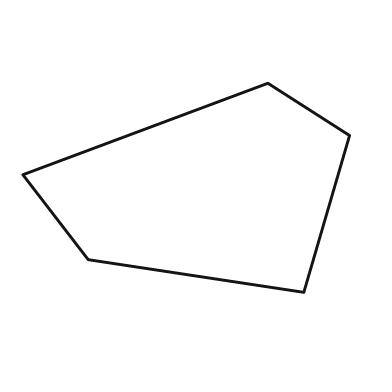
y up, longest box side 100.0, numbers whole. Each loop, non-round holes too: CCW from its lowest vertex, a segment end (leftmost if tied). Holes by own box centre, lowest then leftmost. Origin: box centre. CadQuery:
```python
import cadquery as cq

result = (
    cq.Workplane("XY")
    .moveTo(36.0, -32.0)
    .lineTo(50.0, 16.0)
    .lineTo(25.0, 32.0)
    .lineTo(-50.0, 4.0)
    .lineTo(-30.0, -22.0)
    .close()
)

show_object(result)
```